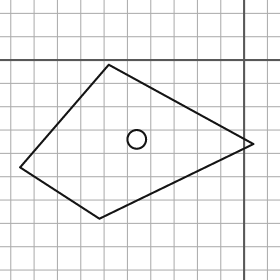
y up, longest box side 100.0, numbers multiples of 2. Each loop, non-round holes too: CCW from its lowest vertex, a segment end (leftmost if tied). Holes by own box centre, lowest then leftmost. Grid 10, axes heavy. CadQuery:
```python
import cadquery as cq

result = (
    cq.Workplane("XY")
    .moveTo(-62.0, -68.0)
    .lineTo(4.0, -36.0)
    .lineTo(-58.0, -2.0)
    .lineTo(-96.0, -46.0)
    .close()
    .moveTo(-46.0, -34.0)
    .circle(4.0)
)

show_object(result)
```